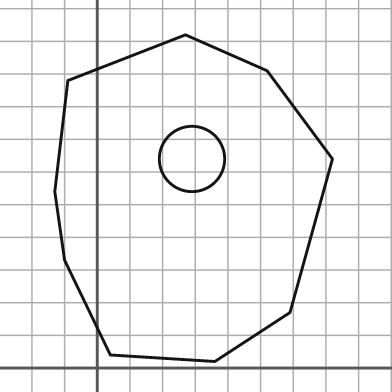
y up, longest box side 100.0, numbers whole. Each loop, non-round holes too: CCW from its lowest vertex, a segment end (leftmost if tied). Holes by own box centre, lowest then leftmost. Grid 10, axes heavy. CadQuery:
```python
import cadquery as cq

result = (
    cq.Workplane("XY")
    .moveTo(36.0, 2.0)
    .lineTo(59.0, 17.0)
    .lineTo(72.0, 64.0)
    .lineTo(52.0, 91.0)
    .lineTo(27.0, 102.0)
    .lineTo(-9.0, 88.0)
    .lineTo(-13.0, 54.0)
    .lineTo(-10.0, 33.0)
    .lineTo(4.0, 4.0)
    .close()
    .moveTo(29.0, 64.0)
    .circle(10.0)
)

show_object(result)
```